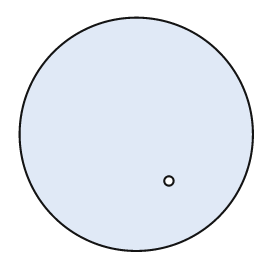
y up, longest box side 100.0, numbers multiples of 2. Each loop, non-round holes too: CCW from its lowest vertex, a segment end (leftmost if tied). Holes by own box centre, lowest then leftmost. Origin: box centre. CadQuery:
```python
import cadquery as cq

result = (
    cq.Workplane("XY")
    .moveTo(0.0, 0.0)
    .circle(50.0)
    .moveTo(14.0, -20.0)
    .circle(2.0)
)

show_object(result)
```